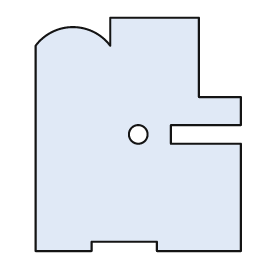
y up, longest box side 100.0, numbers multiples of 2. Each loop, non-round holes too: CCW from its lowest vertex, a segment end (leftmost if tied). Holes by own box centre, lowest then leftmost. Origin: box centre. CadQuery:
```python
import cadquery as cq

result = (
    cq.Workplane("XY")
    .moveTo(-44.0, -50.0)
    .lineTo(-20.0, -50.0)
    .lineTo(-20.0, -46.0)
    .lineTo(8.0, -46.0)
    .lineTo(8.0, -50.0)
    .lineTo(44.0, -50.0)
    .lineTo(44.0, -4.0)
    .lineTo(14.0, -4.0)
    .lineTo(14.0, 4.0)
    .lineTo(44.0, 4.0)
    .lineTo(44.0, 16.0)
    .lineTo(26.0, 16.0)
    .lineTo(26.0, 50.0)
    .lineTo(-12.0, 50.0)
    .lineTo(-12.0, 38.0)
    .threePointArc((-28.0, 46.0), (-44.0, 38.0))
    .close()
    .moveTo(0.0, 0.0)
    .circle(4.0)
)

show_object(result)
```